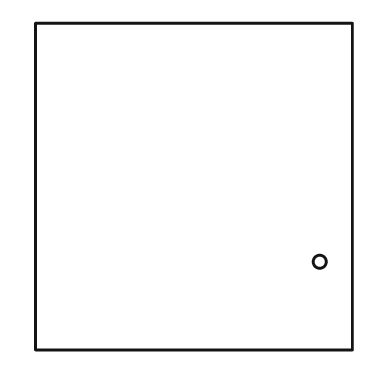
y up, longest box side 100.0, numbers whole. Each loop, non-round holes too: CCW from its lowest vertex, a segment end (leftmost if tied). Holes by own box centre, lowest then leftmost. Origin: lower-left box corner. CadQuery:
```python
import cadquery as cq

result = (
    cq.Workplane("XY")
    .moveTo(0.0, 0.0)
    .lineTo(97.0, 0.0)
    .lineTo(97.0, 100.0)
    .lineTo(0.0, 100.0)
    .close()
    .moveTo(87.0, 27.0)
    .circle(2.0)
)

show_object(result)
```